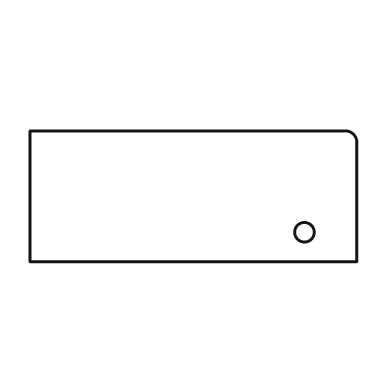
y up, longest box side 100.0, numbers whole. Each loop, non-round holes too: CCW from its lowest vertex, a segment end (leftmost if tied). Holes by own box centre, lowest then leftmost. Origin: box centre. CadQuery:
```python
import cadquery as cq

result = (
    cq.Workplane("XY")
    .moveTo(-50.0, -20.0)
    .lineTo(50.0, -20.0)
    .lineTo(50.0, 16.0)
    .threePointArc((49.0, 19.0), (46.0, 20.0))
    .lineTo(-50.0, 20.0)
    .close()
    .moveTo(34.0, -11.0)
    .circle(3.0)
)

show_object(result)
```